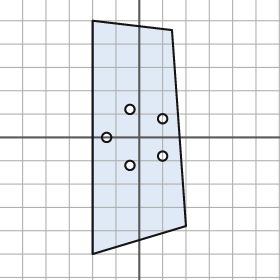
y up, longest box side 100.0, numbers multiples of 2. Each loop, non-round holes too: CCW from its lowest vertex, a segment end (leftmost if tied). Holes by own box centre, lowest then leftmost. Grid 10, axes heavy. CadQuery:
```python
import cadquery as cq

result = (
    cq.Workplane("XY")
    .moveTo(-20.0, -50.0)
    .lineTo(20.0, -38.0)
    .lineTo(14.0, 46.0)
    .lineTo(-20.0, 50.0)
    .close()
    .moveTo(-4.0, -12.0)
    .circle(2.0)
    .moveTo(10.0, -8.0)
    .circle(2.0)
    .moveTo(-14.0, 0.0)
    .circle(2.0)
    .moveTo(10.0, 8.0)
    .circle(2.0)
    .moveTo(-4.0, 12.0)
    .circle(2.0)
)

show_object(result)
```